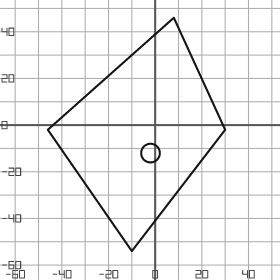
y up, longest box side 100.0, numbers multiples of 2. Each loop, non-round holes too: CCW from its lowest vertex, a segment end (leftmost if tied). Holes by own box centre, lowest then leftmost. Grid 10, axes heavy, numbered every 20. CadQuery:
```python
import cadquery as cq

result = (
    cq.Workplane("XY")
    .moveTo(-10.0, -54.0)
    .lineTo(30.0, -2.0)
    .lineTo(8.0, 46.0)
    .lineTo(-46.0, -2.0)
    .close()
    .moveTo(-2.0, -12.0)
    .circle(4.0)
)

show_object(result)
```